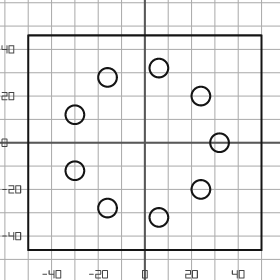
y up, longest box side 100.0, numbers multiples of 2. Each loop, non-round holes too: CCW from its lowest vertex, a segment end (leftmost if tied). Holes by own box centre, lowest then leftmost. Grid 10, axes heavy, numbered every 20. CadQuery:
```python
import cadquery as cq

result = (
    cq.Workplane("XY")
    .moveTo(-50.0, -46.0)
    .lineTo(50.0, -46.0)
    .lineTo(50.0, 46.0)
    .lineTo(-50.0, 46.0)
    .close()
    .moveTo(6.0, -32.0)
    .circle(4.0)
    .moveTo(-16.0, -28.0)
    .circle(4.0)
    .moveTo(24.0, -20.0)
    .circle(4.0)
    .moveTo(-30.0, -12.0)
    .circle(4.0)
    .moveTo(32.0, 0.0)
    .circle(4.0)
    .moveTo(-30.0, 12.0)
    .circle(4.0)
    .moveTo(24.0, 20.0)
    .circle(4.0)
    .moveTo(-16.0, 28.0)
    .circle(4.0)
    .moveTo(6.0, 32.0)
    .circle(4.0)
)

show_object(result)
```